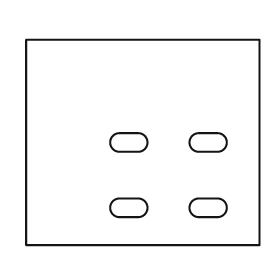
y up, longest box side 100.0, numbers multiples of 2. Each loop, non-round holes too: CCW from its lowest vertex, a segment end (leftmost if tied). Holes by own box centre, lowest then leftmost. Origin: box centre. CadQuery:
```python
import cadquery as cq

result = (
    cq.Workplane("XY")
    .moveTo(-50.0, -44.0)
    .lineTo(50.0, -44.0)
    .lineTo(50.0, 44.0)
    .lineTo(-50.0, 44.0)
    .close()
    .moveTo(-10.0, -32.0)
    .lineTo(-2.0, -32.0)
    .threePointArc((2.0, -28.0), (-2.0, -24.0))
    .lineTo(-10.0, -24.0)
    .threePointArc((-14.0, -28.0), (-10.0, -32.0))
    .close()
    .moveTo(24.0, -32.0)
    .lineTo(32.0, -32.0)
    .threePointArc((36.0, -28.0), (32.0, -24.0))
    .lineTo(24.0, -24.0)
    .threePointArc((20.0, -28.0), (24.0, -32.0))
    .close()
    .moveTo(-10.0, -4.0)
    .lineTo(-2.0, -4.0)
    .threePointArc((2.0, 0.0), (-2.0, 4.0))
    .lineTo(-10.0, 4.0)
    .threePointArc((-14.0, 0.0), (-10.0, -4.0))
    .close()
    .moveTo(24.0, -4.0)
    .lineTo(32.0, -4.0)
    .threePointArc((36.0, 0.0), (32.0, 4.0))
    .lineTo(24.0, 4.0)
    .threePointArc((20.0, 0.0), (24.0, -4.0))
    .close()
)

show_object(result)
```